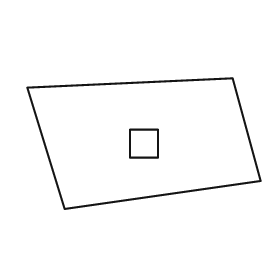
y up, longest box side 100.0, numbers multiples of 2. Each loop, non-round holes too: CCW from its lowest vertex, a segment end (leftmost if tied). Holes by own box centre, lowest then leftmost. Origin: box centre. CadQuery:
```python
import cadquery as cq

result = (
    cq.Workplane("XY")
    .moveTo(-34.0, -28.0)
    .lineTo(50.0, -16.0)
    .lineTo(38.0, 28.0)
    .lineTo(-50.0, 24.0)
    .close()
    .moveTo(-6.0, -6.0)
    .lineTo(6.0, -6.0)
    .lineTo(6.0, 6.0)
    .lineTo(-6.0, 6.0)
    .close()
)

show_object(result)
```